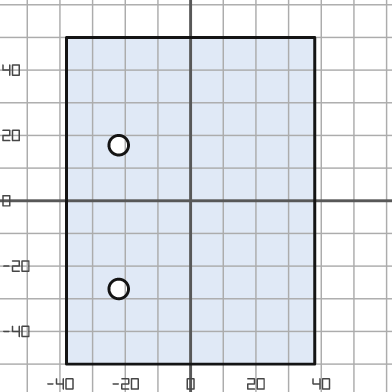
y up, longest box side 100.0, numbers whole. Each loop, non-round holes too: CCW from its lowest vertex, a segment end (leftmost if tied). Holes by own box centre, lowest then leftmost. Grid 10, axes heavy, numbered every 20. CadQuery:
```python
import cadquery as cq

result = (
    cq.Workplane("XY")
    .moveTo(-38.0, -50.0)
    .lineTo(38.0, -50.0)
    .lineTo(38.0, 50.0)
    .lineTo(-38.0, 50.0)
    .close()
    .moveTo(-22.0, -27.0)
    .circle(3.0)
    .moveTo(-22.0, 17.0)
    .circle(3.0)
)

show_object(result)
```